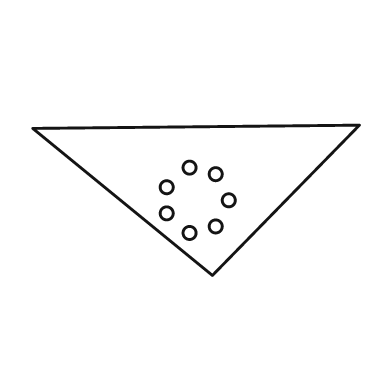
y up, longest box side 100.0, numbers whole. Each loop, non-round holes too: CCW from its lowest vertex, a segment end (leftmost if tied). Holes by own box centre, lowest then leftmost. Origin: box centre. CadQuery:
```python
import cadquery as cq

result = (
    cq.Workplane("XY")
    .moveTo(5.0, -23.0)
    .lineTo(50.0, 23.0)
    .lineTo(-50.0, 22.0)
    .close()
    .moveTo(-2.0, -10.0)
    .circle(2.0)
    .moveTo(6.0, -8.0)
    .circle(2.0)
    .moveTo(-9.0, -4.0)
    .circle(2.0)
    .moveTo(10.0, 0.0)
    .circle(2.0)
    .moveTo(-9.0, 4.0)
    .circle(2.0)
    .moveTo(6.0, 8.0)
    .circle(2.0)
    .moveTo(-2.0, 10.0)
    .circle(2.0)
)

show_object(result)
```